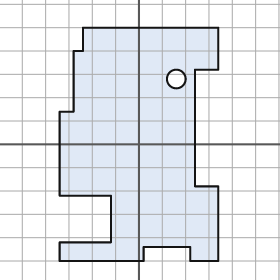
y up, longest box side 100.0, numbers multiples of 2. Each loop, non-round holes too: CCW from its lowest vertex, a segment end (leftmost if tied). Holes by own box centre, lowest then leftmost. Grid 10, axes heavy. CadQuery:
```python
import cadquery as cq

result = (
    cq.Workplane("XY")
    .moveTo(-34.0, -50.0)
    .lineTo(2.0, -50.0)
    .lineTo(2.0, -44.0)
    .lineTo(22.0, -44.0)
    .lineTo(22.0, -50.0)
    .lineTo(34.0, -50.0)
    .lineTo(34.0, -18.0)
    .lineTo(24.0, -18.0)
    .lineTo(24.0, 32.0)
    .lineTo(34.0, 32.0)
    .lineTo(34.0, 50.0)
    .lineTo(-24.0, 50.0)
    .lineTo(-24.0, 40.0)
    .lineTo(-28.0, 40.0)
    .lineTo(-28.0, 14.0)
    .lineTo(-34.0, 14.0)
    .lineTo(-34.0, -22.0)
    .lineTo(-12.0, -22.0)
    .lineTo(-12.0, -42.0)
    .lineTo(-34.0, -42.0)
    .close()
    .moveTo(16.0, 28.0)
    .circle(4.0)
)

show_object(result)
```